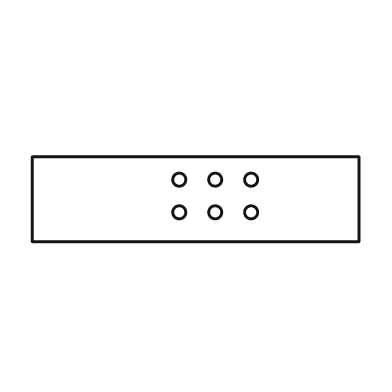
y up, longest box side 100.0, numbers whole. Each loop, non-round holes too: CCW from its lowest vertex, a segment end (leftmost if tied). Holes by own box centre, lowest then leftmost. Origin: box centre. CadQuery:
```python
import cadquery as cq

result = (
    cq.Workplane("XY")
    .moveTo(-50.0, -13.0)
    .lineTo(50.0, -13.0)
    .lineTo(50.0, 13.0)
    .lineTo(-50.0, 13.0)
    .close()
    .moveTo(-5.0, -4.0)
    .circle(2.0)
    .moveTo(6.0, -4.0)
    .circle(2.0)
    .moveTo(17.0, -4.0)
    .circle(2.0)
    .moveTo(-5.0, 6.0)
    .circle(2.0)
    .moveTo(6.0, 6.0)
    .circle(2.0)
    .moveTo(17.0, 6.0)
    .circle(2.0)
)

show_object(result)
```